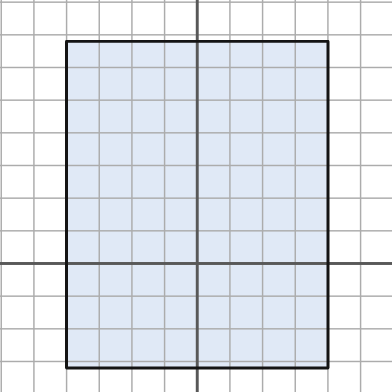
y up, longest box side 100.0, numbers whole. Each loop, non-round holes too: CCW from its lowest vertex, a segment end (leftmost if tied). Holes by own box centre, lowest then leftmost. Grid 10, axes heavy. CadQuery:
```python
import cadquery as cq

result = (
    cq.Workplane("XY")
    .moveTo(-40.0, -32.0)
    .lineTo(40.0, -32.0)
    .lineTo(40.0, 68.0)
    .lineTo(-40.0, 68.0)
    .close()
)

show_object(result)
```